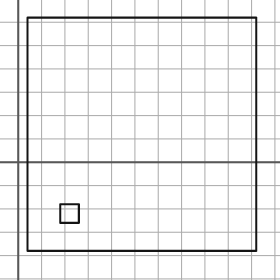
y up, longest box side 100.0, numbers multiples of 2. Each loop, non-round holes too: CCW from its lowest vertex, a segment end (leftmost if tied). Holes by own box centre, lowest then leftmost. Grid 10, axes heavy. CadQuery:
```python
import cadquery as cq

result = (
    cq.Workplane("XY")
    .moveTo(4.0, -38.0)
    .lineTo(102.0, -38.0)
    .lineTo(102.0, 62.0)
    .lineTo(4.0, 62.0)
    .close()
    .moveTo(18.0, -26.0)
    .lineTo(26.0, -26.0)
    .lineTo(26.0, -18.0)
    .lineTo(18.0, -18.0)
    .close()
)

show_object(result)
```